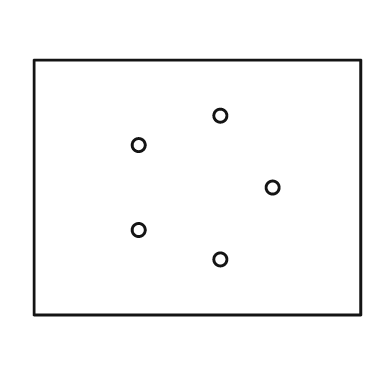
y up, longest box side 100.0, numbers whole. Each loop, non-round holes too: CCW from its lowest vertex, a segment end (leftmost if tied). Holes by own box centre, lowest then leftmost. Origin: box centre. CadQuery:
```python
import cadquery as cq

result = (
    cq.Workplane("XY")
    .moveTo(-50.0, -39.0)
    .lineTo(50.0, -39.0)
    .lineTo(50.0, 39.0)
    .lineTo(-50.0, 39.0)
    .close()
    .moveTo(7.0, -22.0)
    .circle(2.0)
    .moveTo(-18.0, -13.0)
    .circle(2.0)
    .moveTo(23.0, 0.0)
    .circle(2.0)
    .moveTo(-18.0, 13.0)
    .circle(2.0)
    .moveTo(7.0, 22.0)
    .circle(2.0)
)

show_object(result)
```